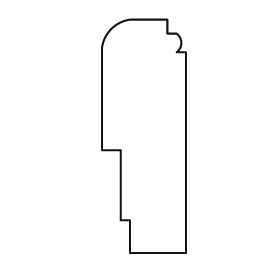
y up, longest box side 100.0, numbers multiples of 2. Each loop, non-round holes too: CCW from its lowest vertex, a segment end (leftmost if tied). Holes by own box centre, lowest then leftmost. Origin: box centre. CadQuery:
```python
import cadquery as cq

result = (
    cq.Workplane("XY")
    .moveTo(-6.0, -50.0)
    .lineTo(18.0, -50.0)
    .lineTo(18.0, 36.0)
    .lineTo(14.0, 36.0)
    .threePointArc((16.0, 40.0), (14.0, 44.0))
    .lineTo(10.0, 44.0)
    .lineTo(10.0, 50.0)
    .lineTo(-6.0, 50.0)
    .threePointArc((-14.0, 46.0), (-18.0, 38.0))
    .lineTo(-18.0, -6.0)
    .lineTo(-10.0, -6.0)
    .lineTo(-10.0, -36.0)
    .lineTo(-6.0, -36.0)
    .close()
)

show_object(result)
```